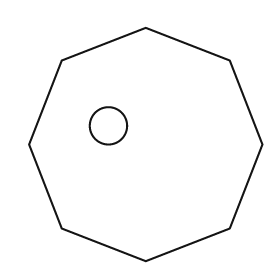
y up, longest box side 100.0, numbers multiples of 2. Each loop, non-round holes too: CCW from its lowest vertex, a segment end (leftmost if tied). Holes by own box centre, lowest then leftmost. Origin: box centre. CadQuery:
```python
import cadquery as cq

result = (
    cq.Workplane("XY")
    .moveTo(0.0, -50.0)
    .lineTo(36.0, -36.0)
    .lineTo(50.0, 0.0)
    .lineTo(36.0, 36.0)
    .lineTo(0.0, 50.0)
    .lineTo(-36.0, 36.0)
    .lineTo(-50.0, 0.0)
    .lineTo(-36.0, -36.0)
    .close()
    .moveTo(-16.0, 8.0)
    .circle(8.0)
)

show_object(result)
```